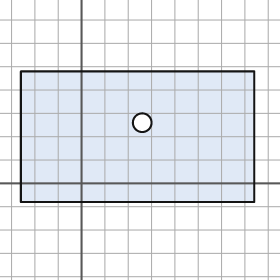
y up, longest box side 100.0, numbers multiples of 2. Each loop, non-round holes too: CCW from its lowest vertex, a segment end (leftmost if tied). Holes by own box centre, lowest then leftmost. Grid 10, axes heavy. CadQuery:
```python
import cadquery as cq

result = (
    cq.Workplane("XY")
    .moveTo(-26.0, -8.0)
    .lineTo(74.0, -8.0)
    .lineTo(74.0, 48.0)
    .lineTo(-26.0, 48.0)
    .close()
    .moveTo(26.0, 26.0)
    .circle(4.0)
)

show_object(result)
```